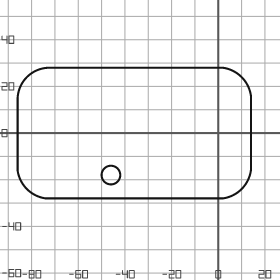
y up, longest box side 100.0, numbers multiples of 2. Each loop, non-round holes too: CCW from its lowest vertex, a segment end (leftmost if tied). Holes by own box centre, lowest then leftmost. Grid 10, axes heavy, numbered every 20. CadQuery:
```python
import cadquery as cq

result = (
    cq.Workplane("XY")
    .moveTo(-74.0, -28.0)
    .lineTo(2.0, -28.0)
    .threePointArc((10.0, -24.0), (14.0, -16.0))
    .lineTo(14.0, 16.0)
    .threePointArc((10.0, 24.0), (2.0, 28.0))
    .lineTo(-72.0, 28.0)
    .threePointArc((-82.0, 24.0), (-86.0, 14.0))
    .lineTo(-86.0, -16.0)
    .threePointArc((-82.0, -24.0), (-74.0, -28.0))
    .close()
    .moveTo(-46.0, -18.0)
    .circle(4.0)
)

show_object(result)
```